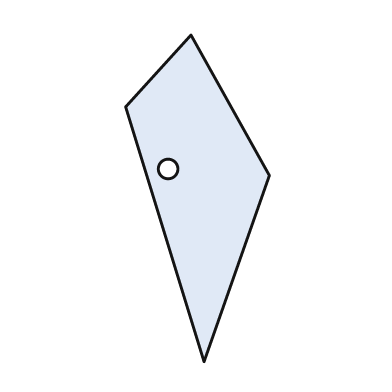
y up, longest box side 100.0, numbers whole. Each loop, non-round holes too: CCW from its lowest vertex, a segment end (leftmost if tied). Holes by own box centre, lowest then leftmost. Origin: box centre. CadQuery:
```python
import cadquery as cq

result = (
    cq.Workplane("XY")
    .moveTo(2.0, -50.0)
    .lineTo(22.0, 7.0)
    .lineTo(-2.0, 50.0)
    .lineTo(-22.0, 28.0)
    .close()
    .moveTo(-9.0, 9.0)
    .circle(3.0)
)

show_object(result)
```